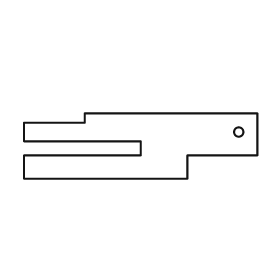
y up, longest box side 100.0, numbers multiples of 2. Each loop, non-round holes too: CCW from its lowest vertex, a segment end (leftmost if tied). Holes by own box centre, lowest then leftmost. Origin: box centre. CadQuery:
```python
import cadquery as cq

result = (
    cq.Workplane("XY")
    .moveTo(-50.0, -14.0)
    .lineTo(20.0, -14.0)
    .lineTo(20.0, -4.0)
    .lineTo(50.0, -4.0)
    .lineTo(50.0, 14.0)
    .lineTo(-24.0, 14.0)
    .lineTo(-24.0, 10.0)
    .lineTo(-50.0, 10.0)
    .lineTo(-50.0, 2.0)
    .lineTo(0.0, 2.0)
    .lineTo(0.0, -4.0)
    .lineTo(-50.0, -4.0)
    .close()
    .moveTo(42.0, 6.0)
    .circle(2.0)
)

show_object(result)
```